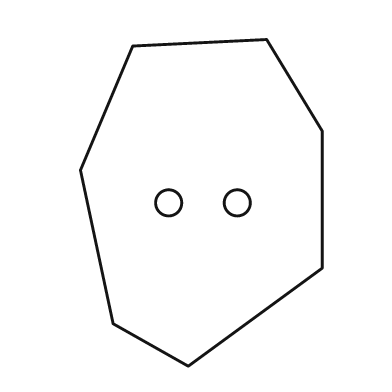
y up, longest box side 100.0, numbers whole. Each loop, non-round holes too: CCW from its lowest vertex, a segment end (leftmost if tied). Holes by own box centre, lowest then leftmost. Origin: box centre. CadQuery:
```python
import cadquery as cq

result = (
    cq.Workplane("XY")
    .moveTo(-4.0, -50.0)
    .lineTo(37.0, -20.0)
    .lineTo(37.0, 22.0)
    .lineTo(20.0, 50.0)
    .lineTo(-21.0, 48.0)
    .lineTo(-37.0, 10.0)
    .lineTo(-27.0, -37.0)
    .close()
    .moveTo(-10.0, 0.0)
    .circle(4.0)
    .moveTo(11.0, 0.0)
    .circle(4.0)
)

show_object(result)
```